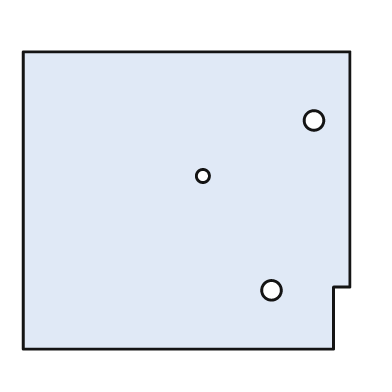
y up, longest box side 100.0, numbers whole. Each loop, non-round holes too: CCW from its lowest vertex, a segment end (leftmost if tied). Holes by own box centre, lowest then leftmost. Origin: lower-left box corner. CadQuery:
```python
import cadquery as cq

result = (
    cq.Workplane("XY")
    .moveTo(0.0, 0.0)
    .lineTo(95.0, 0.0)
    .lineTo(95.0, 19.0)
    .lineTo(100.0, 19.0)
    .lineTo(100.0, 91.0)
    .lineTo(0.0, 91.0)
    .close()
    .moveTo(76.0, 18.0)
    .circle(3.0)
    .moveTo(55.0, 53.0)
    .circle(2.0)
    .moveTo(89.0, 70.0)
    .circle(3.0)
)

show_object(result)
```